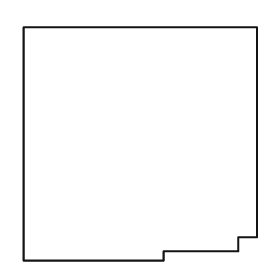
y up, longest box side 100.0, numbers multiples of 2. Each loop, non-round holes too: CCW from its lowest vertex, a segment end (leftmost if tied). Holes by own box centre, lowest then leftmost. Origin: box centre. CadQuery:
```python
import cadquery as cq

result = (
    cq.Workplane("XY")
    .moveTo(-50.0, -50.0)
    .lineTo(10.0, -50.0)
    .lineTo(10.0, -46.0)
    .lineTo(42.0, -46.0)
    .lineTo(42.0, -40.0)
    .lineTo(50.0, -40.0)
    .lineTo(50.0, 50.0)
    .lineTo(-50.0, 50.0)
    .close()
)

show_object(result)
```